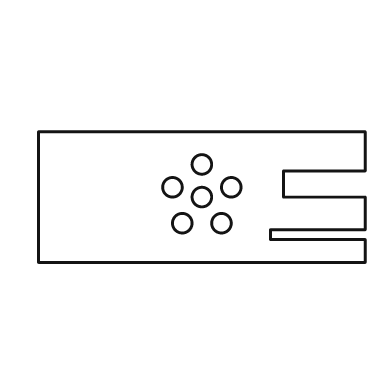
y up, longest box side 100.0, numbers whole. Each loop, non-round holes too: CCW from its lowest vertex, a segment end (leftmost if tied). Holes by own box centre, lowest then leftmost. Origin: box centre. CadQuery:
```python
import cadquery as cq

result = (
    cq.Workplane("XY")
    .moveTo(-50.0, -20.0)
    .lineTo(50.0, -20.0)
    .lineTo(50.0, -13.0)
    .lineTo(21.0, -13.0)
    .lineTo(21.0, -10.0)
    .lineTo(50.0, -10.0)
    .lineTo(50.0, 0.0)
    .lineTo(25.0, 0.0)
    .lineTo(25.0, 8.0)
    .lineTo(50.0, 8.0)
    .lineTo(50.0, 20.0)
    .lineTo(-50.0, 20.0)
    .close()
    .moveTo(-6.0, -8.0)
    .circle(3.0)
    .moveTo(6.0, -8.0)
    .circle(3.0)
    .moveTo(0.0, 0.0)
    .circle(3.0)
    .moveTo(-9.0, 3.0)
    .circle(3.0)
    .moveTo(9.0, 3.0)
    .circle(3.0)
    .moveTo(0.0, 10.0)
    .circle(3.0)
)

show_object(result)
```